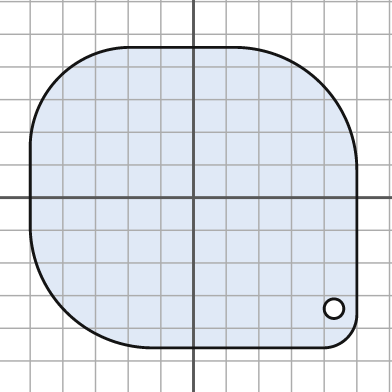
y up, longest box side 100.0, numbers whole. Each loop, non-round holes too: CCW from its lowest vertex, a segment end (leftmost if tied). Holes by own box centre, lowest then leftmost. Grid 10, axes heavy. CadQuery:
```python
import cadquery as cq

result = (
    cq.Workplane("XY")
    .moveTo(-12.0, -46.0)
    .lineTo(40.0, -46.0)
    .threePointArc((47.0, -43.0), (50.0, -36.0))
    .lineTo(50.0, 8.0)
    .threePointArc((39.0, 35.0), (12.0, 46.0))
    .lineTo(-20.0, 46.0)
    .threePointArc((-41.0, 37.0), (-50.0, 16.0))
    .lineTo(-50.0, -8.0)
    .threePointArc((-39.0, -35.0), (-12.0, -46.0))
    .close()
    .moveTo(43.0, -34.0)
    .circle(3.0)
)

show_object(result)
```